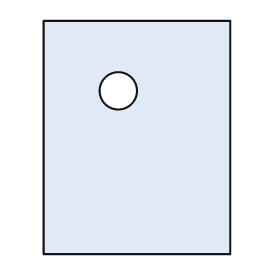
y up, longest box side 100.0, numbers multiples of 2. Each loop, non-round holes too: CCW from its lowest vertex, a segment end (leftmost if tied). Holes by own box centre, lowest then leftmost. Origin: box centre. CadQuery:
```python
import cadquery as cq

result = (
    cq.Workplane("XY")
    .moveTo(-40.0, -50.0)
    .lineTo(40.0, -50.0)
    .lineTo(40.0, 50.0)
    .lineTo(-40.0, 50.0)
    .close()
    .moveTo(-8.0, 20.0)
    .circle(8.0)
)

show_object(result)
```